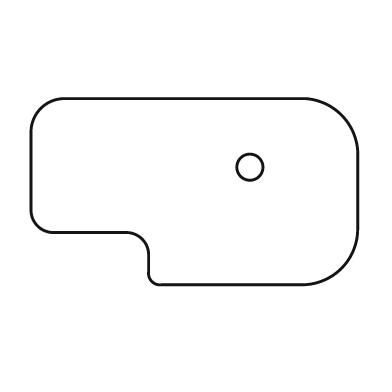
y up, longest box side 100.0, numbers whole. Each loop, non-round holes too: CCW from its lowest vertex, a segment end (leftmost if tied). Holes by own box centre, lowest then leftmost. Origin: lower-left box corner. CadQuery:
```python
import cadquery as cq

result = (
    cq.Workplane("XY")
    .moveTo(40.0, 0.0)
    .lineTo(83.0, 0.0)
    .threePointArc((95.0, 5.0), (100.0, 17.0))
    .lineTo(100.0, 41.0)
    .threePointArc((95.0, 52.0), (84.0, 57.0))
    .lineTo(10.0, 57.0)
    .threePointArc((3.0, 54.0), (0.0, 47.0))
    .lineTo(0.0, 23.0)
    .threePointArc((2.0, 18.0), (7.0, 16.0))
    .lineTo(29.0, 16.0)
    .threePointArc((34.0, 14.0), (36.0, 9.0))
    .lineTo(36.0, 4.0)
    .threePointArc((37.0, 1.0), (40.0, 0.0))
    .close()
    .moveTo(67.0, 36.0)
    .circle(4.0)
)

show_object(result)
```